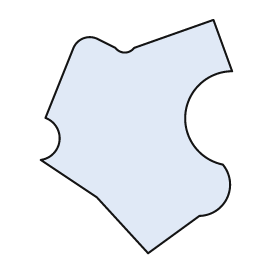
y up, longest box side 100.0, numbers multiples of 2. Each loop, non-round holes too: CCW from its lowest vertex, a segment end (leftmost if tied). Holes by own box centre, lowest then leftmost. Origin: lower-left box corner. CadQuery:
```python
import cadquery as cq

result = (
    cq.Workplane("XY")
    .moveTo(46.0, 0.0)
    .lineTo(68.0, 16.0)
    .threePointArc((80.0, 24.0), (78.0, 38.0))
    .threePointArc((62.0, 60.0), (82.0, 78.0))
    .lineTo(74.0, 100.0)
    .lineTo(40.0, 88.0)
    .threePointArc((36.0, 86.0), (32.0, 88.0))
    .lineTo(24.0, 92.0)
    .threePointArc((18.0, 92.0), (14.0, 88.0))
    .lineTo(2.0, 58.0)
    .threePointArc((8.0, 48.0), (0.0, 40.0))
    .lineTo(24.0, 24.0)
    .close()
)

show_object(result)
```